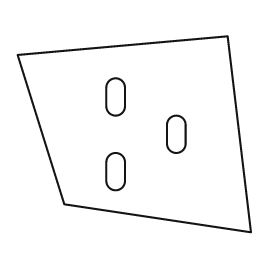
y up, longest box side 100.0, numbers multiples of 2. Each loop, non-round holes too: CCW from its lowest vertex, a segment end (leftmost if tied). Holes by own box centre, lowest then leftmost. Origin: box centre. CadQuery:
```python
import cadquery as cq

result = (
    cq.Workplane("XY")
    .moveTo(50.0, -42.0)
    .lineTo(40.0, 42.0)
    .lineTo(-50.0, 34.0)
    .lineTo(-30.0, -30.0)
    .close()
    .moveTo(-12.0, -20.0)
    .threePointArc((-8.0, -24.0), (-4.0, -20.0))
    .lineTo(-4.0, -12.0)
    .threePointArc((-8.0, -8.0), (-12.0, -12.0))
    .close()
    .moveTo(14.0, -4.0)
    .threePointArc((18.0, -8.0), (22.0, -4.0))
    .lineTo(22.0, 4.0)
    .threePointArc((18.0, 8.0), (14.0, 4.0))
    .close()
    .moveTo(-12.0, 12.0)
    .threePointArc((-8.0, 8.0), (-4.0, 12.0))
    .lineTo(-4.0, 20.0)
    .threePointArc((-8.0, 24.0), (-12.0, 20.0))
    .close()
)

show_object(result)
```